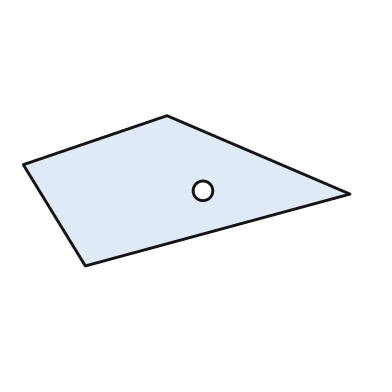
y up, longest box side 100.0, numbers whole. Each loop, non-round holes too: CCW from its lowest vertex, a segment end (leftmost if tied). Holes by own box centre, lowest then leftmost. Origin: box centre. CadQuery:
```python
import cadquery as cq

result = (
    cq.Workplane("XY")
    .moveTo(-31.0, -23.0)
    .lineTo(50.0, -1.0)
    .lineTo(-6.0, 23.0)
    .lineTo(-50.0, 8.0)
    .close()
    .moveTo(5.0, 0.0)
    .circle(3.0)
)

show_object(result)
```